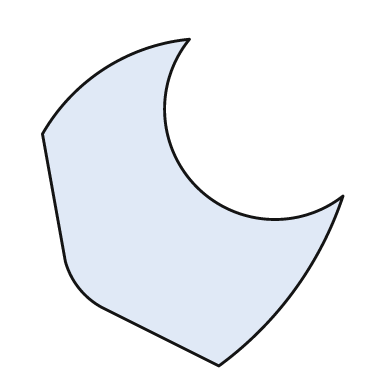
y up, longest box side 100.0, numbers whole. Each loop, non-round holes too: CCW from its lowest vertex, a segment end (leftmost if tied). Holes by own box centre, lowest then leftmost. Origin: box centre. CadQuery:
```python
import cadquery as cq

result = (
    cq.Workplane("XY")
    .moveTo(8.0, -50.0)
    .threePointArc((31.0, -27.0), (46.0, 2.0))
    .threePointArc((1.0, 5.0), (-1.0, 50.0))
    .threePointArc((-27.0, 41.0), (-46.0, 21.0))
    .lineTo(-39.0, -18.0)
    .threePointArc((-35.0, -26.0), (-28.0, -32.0))
    .close()
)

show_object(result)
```